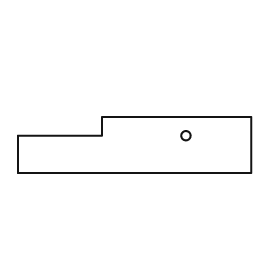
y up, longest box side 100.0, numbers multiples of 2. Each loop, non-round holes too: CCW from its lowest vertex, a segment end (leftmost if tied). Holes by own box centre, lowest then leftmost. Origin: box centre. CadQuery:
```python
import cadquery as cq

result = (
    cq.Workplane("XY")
    .moveTo(-50.0, -12.0)
    .lineTo(50.0, -12.0)
    .lineTo(50.0, 12.0)
    .lineTo(-14.0, 12.0)
    .lineTo(-14.0, 4.0)
    .lineTo(-50.0, 4.0)
    .close()
    .moveTo(22.0, 4.0)
    .circle(2.0)
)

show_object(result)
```